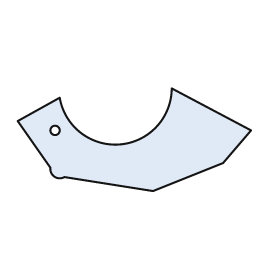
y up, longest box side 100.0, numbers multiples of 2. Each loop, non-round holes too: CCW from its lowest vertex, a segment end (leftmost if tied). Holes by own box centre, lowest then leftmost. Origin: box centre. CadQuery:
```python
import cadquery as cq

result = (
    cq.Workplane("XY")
    .moveTo(8.0, -22.0)
    .lineTo(38.0, -10.0)
    .lineTo(50.0, 4.0)
    .lineTo(16.0, 22.0)
    .threePointArc((-6.0, -2.0), (-32.0, 18.0))
    .lineTo(-50.0, 8.0)
    .lineTo(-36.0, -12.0)
    .threePointArc((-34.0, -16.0), (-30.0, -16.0))
    .close()
    .moveTo(-34.0, 4.0)
    .circle(2.0)
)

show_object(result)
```